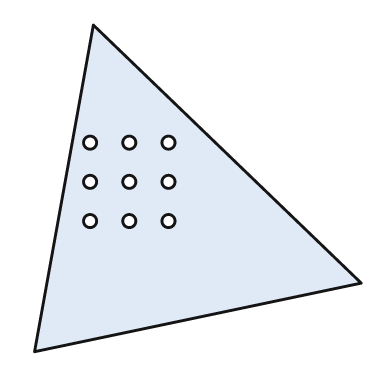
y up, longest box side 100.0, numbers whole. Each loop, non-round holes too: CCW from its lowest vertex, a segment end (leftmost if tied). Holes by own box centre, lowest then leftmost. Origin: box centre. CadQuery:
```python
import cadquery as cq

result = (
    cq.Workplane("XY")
    .moveTo(-50.0, -50.0)
    .lineTo(50.0, -29.0)
    .lineTo(-32.0, 50.0)
    .close()
    .moveTo(-33.0, -10.0)
    .circle(2.0)
    .moveTo(-21.0, -10.0)
    .circle(2.0)
    .moveTo(-9.0, -10.0)
    .circle(2.0)
    .moveTo(-33.0, 2.0)
    .circle(2.0)
    .moveTo(-21.0, 2.0)
    .circle(2.0)
    .moveTo(-9.0, 2.0)
    .circle(2.0)
    .moveTo(-33.0, 14.0)
    .circle(2.0)
    .moveTo(-21.0, 14.0)
    .circle(2.0)
    .moveTo(-9.0, 14.0)
    .circle(2.0)
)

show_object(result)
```